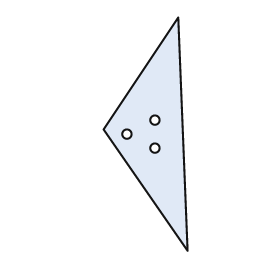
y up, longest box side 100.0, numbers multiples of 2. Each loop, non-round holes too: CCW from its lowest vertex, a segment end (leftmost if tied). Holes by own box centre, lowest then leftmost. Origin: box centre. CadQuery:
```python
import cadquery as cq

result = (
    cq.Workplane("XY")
    .moveTo(18.0, -50.0)
    .lineTo(14.0, 50.0)
    .lineTo(-18.0, 2.0)
    .close()
    .moveTo(4.0, -6.0)
    .circle(2.0)
    .moveTo(-8.0, 0.0)
    .circle(2.0)
    .moveTo(4.0, 6.0)
    .circle(2.0)
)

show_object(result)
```